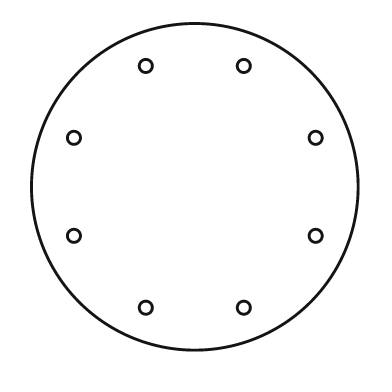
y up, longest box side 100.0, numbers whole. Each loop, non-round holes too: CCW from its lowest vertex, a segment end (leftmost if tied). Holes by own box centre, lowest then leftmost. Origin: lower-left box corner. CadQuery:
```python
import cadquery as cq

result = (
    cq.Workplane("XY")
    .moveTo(50.0, 50.0)
    .circle(50.0)
    .moveTo(35.0, 13.0)
    .circle(2.0)
    .moveTo(65.0, 13.0)
    .circle(2.0)
    .moveTo(13.0, 35.0)
    .circle(2.0)
    .moveTo(87.0, 35.0)
    .circle(2.0)
    .moveTo(13.0, 65.0)
    .circle(2.0)
    .moveTo(87.0, 65.0)
    .circle(2.0)
    .moveTo(35.0, 87.0)
    .circle(2.0)
    .moveTo(65.0, 87.0)
    .circle(2.0)
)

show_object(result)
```